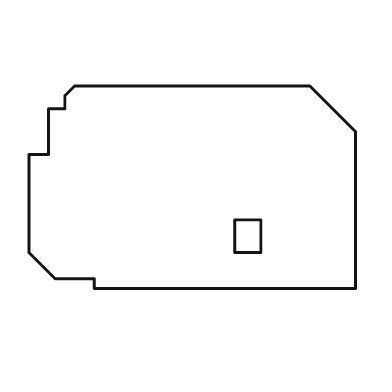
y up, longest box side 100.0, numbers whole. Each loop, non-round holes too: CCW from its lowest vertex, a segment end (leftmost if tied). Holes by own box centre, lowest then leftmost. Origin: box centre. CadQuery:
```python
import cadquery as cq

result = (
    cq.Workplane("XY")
    .moveTo(-30.0, -31.0)
    .lineTo(50.0, -31.0)
    .lineTo(50.0, 17.0)
    .lineTo(36.0, 31.0)
    .lineTo(-36.0, 31.0)
    .lineTo(-39.0, 28.0)
    .lineTo(-39.0, 24.0)
    .lineTo(-44.0, 24.0)
    .lineTo(-44.0, 10.0)
    .lineTo(-50.0, 10.0)
    .lineTo(-50.0, -20.0)
    .lineTo(-42.0, -28.0)
    .lineTo(-30.0, -28.0)
    .close()
    .moveTo(13.0, -20.0)
    .lineTo(21.0, -20.0)
    .lineTo(21.0, -10.0)
    .lineTo(13.0, -10.0)
    .close()
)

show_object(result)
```